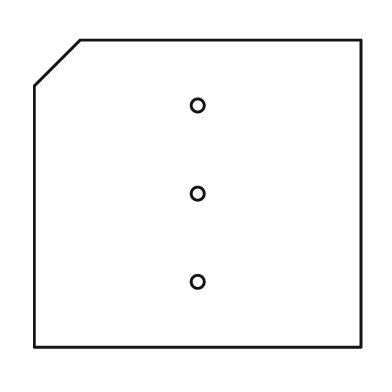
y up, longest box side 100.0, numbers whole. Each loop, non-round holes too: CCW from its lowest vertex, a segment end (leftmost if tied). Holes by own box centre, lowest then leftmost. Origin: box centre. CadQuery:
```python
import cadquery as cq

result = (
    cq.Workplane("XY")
    .moveTo(-50.0, -47.0)
    .lineTo(50.0, -47.0)
    .lineTo(50.0, 47.0)
    .lineTo(-36.0, 47.0)
    .lineTo(-50.0, 33.0)
    .close()
    .moveTo(0.0, -27.0)
    .circle(2.0)
    .moveTo(0.0, 0.0)
    .circle(2.0)
    .moveTo(0.0, 27.0)
    .circle(2.0)
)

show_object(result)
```